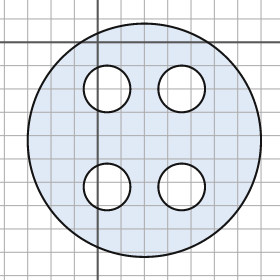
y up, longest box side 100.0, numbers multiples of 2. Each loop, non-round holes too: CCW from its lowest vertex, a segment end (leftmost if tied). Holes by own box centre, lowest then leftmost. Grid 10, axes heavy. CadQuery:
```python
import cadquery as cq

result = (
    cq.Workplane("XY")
    .moveTo(20.0, -42.0)
    .circle(50.0)
    .moveTo(4.0, -62.0)
    .circle(10.0)
    .moveTo(36.0, -62.0)
    .circle(10.0)
    .moveTo(4.0, -20.0)
    .circle(10.0)
    .moveTo(36.0, -20.0)
    .circle(10.0)
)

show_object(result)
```